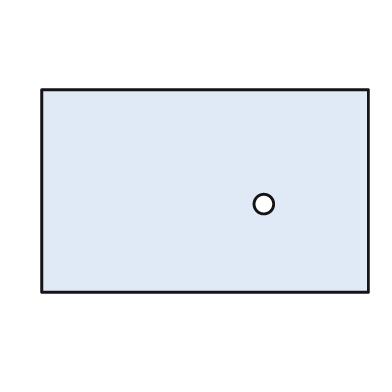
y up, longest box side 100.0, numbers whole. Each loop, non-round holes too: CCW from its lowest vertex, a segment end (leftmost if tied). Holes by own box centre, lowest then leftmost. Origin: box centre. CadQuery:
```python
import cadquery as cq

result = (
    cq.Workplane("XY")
    .moveTo(-50.0, -31.0)
    .lineTo(50.0, -31.0)
    .lineTo(50.0, 31.0)
    .lineTo(-50.0, 31.0)
    .close()
    .moveTo(18.0, -4.0)
    .circle(3.0)
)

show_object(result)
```